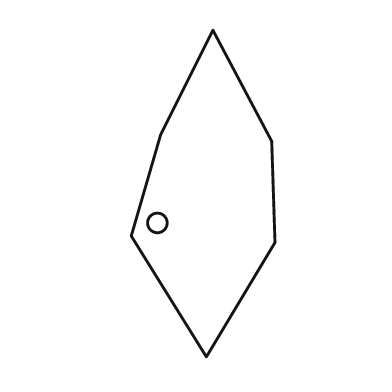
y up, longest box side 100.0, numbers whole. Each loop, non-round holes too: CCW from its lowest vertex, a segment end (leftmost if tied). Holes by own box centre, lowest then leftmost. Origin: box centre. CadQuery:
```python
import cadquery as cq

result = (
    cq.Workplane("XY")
    .moveTo(1.0, -50.0)
    .lineTo(22.0, -15.0)
    .lineTo(21.0, 16.0)
    .lineTo(3.0, 50.0)
    .lineTo(-13.0, 18.0)
    .lineTo(-22.0, -13.0)
    .close()
    .moveTo(-14.0, -9.0)
    .circle(3.0)
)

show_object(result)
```